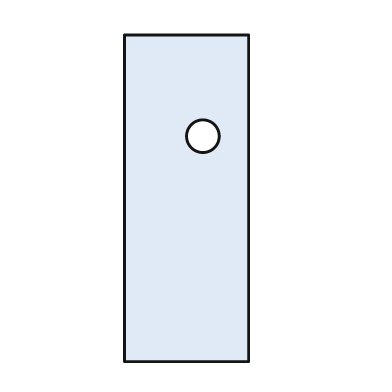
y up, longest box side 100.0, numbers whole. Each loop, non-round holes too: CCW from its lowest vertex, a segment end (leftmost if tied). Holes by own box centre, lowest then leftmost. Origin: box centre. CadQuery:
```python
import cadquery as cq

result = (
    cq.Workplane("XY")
    .moveTo(-19.0, -50.0)
    .lineTo(19.0, -50.0)
    .lineTo(19.0, 50.0)
    .lineTo(-19.0, 50.0)
    .close()
    .moveTo(5.0, 19.0)
    .circle(5.0)
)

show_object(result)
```